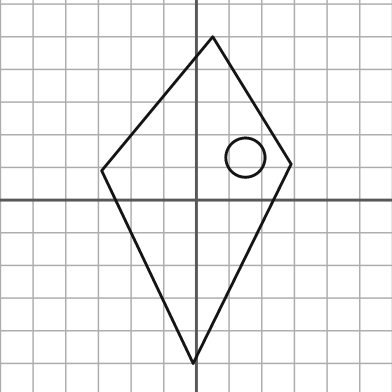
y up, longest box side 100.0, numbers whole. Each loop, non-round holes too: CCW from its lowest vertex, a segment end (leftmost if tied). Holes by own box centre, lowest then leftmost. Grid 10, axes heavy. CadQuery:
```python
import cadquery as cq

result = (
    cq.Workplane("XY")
    .moveTo(-1.0, -50.0)
    .lineTo(29.0, 11.0)
    .lineTo(5.0, 50.0)
    .lineTo(-29.0, 9.0)
    .close()
    .moveTo(15.0, 13.0)
    .circle(6.0)
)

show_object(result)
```